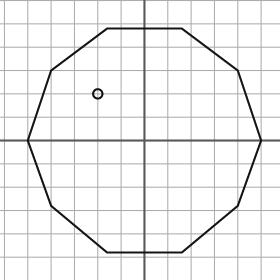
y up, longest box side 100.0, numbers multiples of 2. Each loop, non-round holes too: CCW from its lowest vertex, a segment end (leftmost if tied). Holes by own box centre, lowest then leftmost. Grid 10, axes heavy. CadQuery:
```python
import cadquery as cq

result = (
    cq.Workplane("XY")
    .moveTo(-16.0, -48.0)
    .lineTo(16.0, -48.0)
    .lineTo(40.0, -28.0)
    .lineTo(50.0, 0.0)
    .lineTo(40.0, 30.0)
    .lineTo(16.0, 48.0)
    .lineTo(-16.0, 48.0)
    .lineTo(-40.0, 30.0)
    .lineTo(-50.0, 0.0)
    .lineTo(-40.0, -28.0)
    .close()
    .moveTo(-20.0, 20.0)
    .circle(2.0)
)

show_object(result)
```